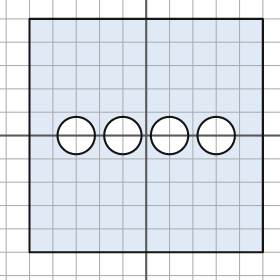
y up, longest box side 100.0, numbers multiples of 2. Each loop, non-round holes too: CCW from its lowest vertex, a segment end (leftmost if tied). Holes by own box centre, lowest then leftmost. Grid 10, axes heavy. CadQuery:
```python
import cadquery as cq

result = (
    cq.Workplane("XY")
    .moveTo(-50.0, -50.0)
    .lineTo(50.0, -50.0)
    .lineTo(50.0, 50.0)
    .lineTo(-50.0, 50.0)
    .close()
    .moveTo(-30.0, 0.0)
    .circle(8.0)
    .moveTo(-10.0, 0.0)
    .circle(8.0)
    .moveTo(10.0, 0.0)
    .circle(8.0)
    .moveTo(30.0, 0.0)
    .circle(8.0)
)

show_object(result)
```